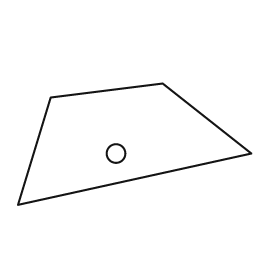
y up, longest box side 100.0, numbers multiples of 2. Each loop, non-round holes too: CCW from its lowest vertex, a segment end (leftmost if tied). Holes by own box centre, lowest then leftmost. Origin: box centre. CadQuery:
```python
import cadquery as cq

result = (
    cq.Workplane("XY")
    .moveTo(-50.0, -26.0)
    .lineTo(50.0, -4.0)
    .lineTo(12.0, 26.0)
    .lineTo(-36.0, 20.0)
    .close()
    .moveTo(-8.0, -4.0)
    .circle(4.0)
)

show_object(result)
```